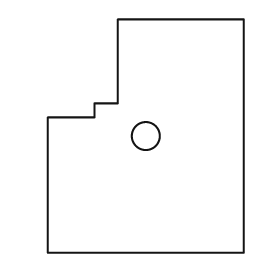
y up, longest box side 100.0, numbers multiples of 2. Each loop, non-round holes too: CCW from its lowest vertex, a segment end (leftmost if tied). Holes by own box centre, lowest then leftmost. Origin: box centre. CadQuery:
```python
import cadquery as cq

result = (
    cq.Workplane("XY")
    .moveTo(-42.0, -50.0)
    .lineTo(42.0, -50.0)
    .lineTo(42.0, 50.0)
    .lineTo(-12.0, 50.0)
    .lineTo(-12.0, 14.0)
    .lineTo(-22.0, 14.0)
    .lineTo(-22.0, 8.0)
    .lineTo(-42.0, 8.0)
    .close()
    .moveTo(0.0, 0.0)
    .circle(6.0)
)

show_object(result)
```